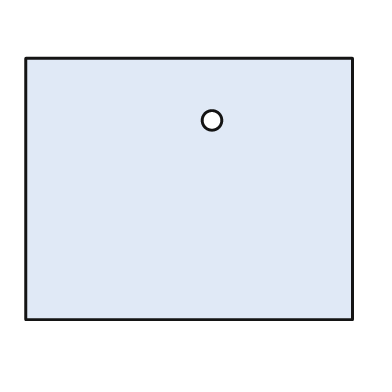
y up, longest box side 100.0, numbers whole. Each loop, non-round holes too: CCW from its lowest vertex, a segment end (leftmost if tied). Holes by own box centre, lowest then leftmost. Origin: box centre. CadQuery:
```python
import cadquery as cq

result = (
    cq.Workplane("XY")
    .moveTo(-50.0, -40.0)
    .lineTo(50.0, -40.0)
    .lineTo(50.0, 40.0)
    .lineTo(-50.0, 40.0)
    .close()
    .moveTo(7.0, 21.0)
    .circle(3.0)
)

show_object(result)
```